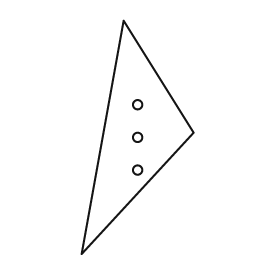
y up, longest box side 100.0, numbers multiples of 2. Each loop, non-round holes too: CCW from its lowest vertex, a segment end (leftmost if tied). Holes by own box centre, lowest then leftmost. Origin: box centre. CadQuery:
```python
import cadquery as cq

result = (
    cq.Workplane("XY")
    .moveTo(-24.0, -50.0)
    .lineTo(24.0, 2.0)
    .lineTo(-6.0, 50.0)
    .close()
    .moveTo(0.0, -14.0)
    .circle(2.0)
    .moveTo(0.0, 0.0)
    .circle(2.0)
    .moveTo(0.0, 14.0)
    .circle(2.0)
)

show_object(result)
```